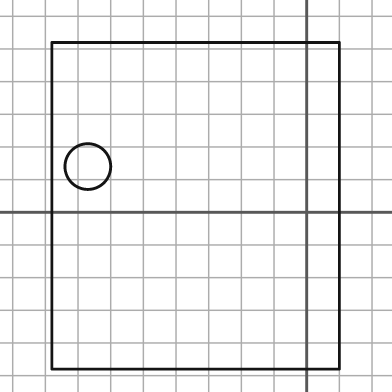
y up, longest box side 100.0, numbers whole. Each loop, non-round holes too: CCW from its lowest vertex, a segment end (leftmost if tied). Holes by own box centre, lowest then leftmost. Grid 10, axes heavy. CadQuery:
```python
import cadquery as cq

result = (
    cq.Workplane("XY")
    .moveTo(-78.0, -48.0)
    .lineTo(10.0, -48.0)
    .lineTo(10.0, 52.0)
    .lineTo(-78.0, 52.0)
    .close()
    .moveTo(-67.0, 14.0)
    .circle(7.0)
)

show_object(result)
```